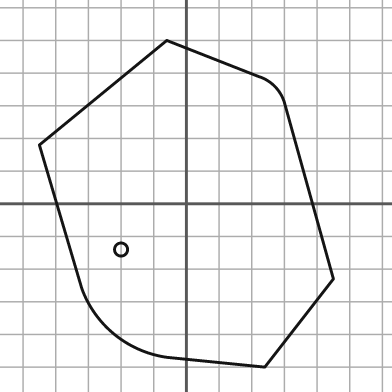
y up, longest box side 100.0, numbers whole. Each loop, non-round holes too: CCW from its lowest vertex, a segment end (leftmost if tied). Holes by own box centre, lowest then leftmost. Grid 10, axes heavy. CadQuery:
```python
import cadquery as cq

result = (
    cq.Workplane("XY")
    .moveTo(24.0, -50.0)
    .lineTo(45.0, -23.0)
    .lineTo(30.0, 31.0)
    .threePointArc((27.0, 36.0), (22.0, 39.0))
    .lineTo(-6.0, 50.0)
    .lineTo(-45.0, 18.0)
    .lineTo(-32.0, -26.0)
    .threePointArc((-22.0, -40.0), (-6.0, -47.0))
    .close()
    .moveTo(-20.0, -14.0)
    .circle(2.0)
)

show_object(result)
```